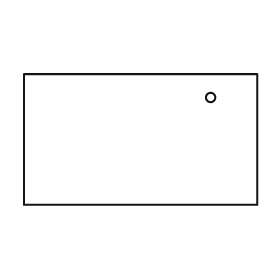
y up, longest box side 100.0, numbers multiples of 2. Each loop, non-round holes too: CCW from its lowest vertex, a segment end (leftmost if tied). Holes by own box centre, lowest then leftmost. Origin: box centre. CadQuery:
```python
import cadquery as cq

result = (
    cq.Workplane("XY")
    .moveTo(-50.0, -28.0)
    .lineTo(50.0, -28.0)
    .lineTo(50.0, 28.0)
    .lineTo(-50.0, 28.0)
    .close()
    .moveTo(30.0, 18.0)
    .circle(2.0)
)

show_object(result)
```